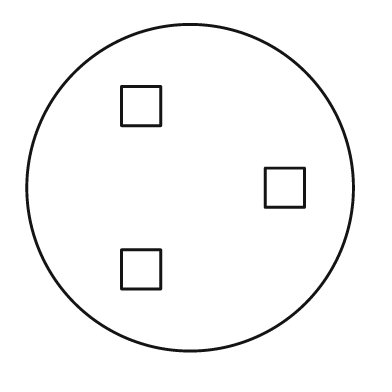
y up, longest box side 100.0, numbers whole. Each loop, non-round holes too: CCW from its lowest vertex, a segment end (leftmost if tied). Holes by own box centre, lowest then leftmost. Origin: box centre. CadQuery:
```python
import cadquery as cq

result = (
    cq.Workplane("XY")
    .moveTo(0.0, 0.0)
    .circle(50.0)
    .moveTo(-21.0, -31.0)
    .lineTo(-9.0, -31.0)
    .lineTo(-9.0, -19.0)
    .lineTo(-21.0, -19.0)
    .close()
    .moveTo(23.0, -6.0)
    .lineTo(35.0, -6.0)
    .lineTo(35.0, 6.0)
    .lineTo(23.0, 6.0)
    .close()
    .moveTo(-21.0, 19.0)
    .lineTo(-9.0, 19.0)
    .lineTo(-9.0, 31.0)
    .lineTo(-21.0, 31.0)
    .close()
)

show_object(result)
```